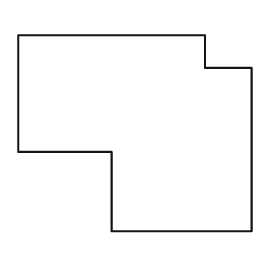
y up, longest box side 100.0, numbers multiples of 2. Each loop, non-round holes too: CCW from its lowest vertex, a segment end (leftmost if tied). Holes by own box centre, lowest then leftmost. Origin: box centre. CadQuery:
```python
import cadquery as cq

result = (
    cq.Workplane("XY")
    .moveTo(-10.0, -42.0)
    .lineTo(50.0, -42.0)
    .lineTo(50.0, 28.0)
    .lineTo(30.0, 28.0)
    .lineTo(30.0, 42.0)
    .lineTo(-50.0, 42.0)
    .lineTo(-50.0, -8.0)
    .lineTo(-10.0, -8.0)
    .close()
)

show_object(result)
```